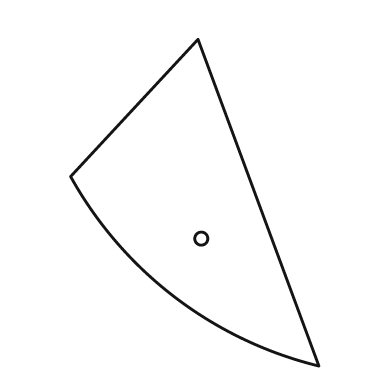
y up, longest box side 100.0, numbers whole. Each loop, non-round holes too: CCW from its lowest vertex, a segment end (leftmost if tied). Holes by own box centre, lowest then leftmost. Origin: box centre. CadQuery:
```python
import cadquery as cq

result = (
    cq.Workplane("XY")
    .moveTo(38.0, -50.0)
    .lineTo(1.0, 50.0)
    .lineTo(-38.0, 8.0)
    .threePointArc((-6.0, -29.0), (38.0, -50.0))
    .close()
    .moveTo(2.0, -11.0)
    .circle(2.0)
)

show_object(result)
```